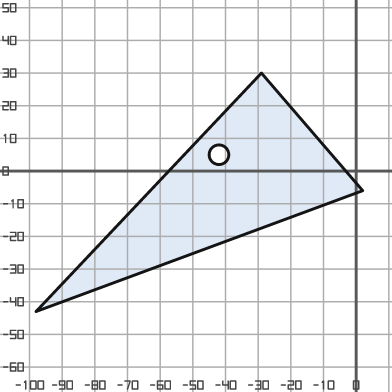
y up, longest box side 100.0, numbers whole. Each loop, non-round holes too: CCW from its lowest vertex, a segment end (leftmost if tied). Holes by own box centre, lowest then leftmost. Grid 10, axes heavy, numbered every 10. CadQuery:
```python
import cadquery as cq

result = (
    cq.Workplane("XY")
    .moveTo(-98.0, -43.0)
    .lineTo(2.0, -6.0)
    .lineTo(-29.0, 30.0)
    .close()
    .moveTo(-42.0, 5.0)
    .circle(3.0)
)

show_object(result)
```